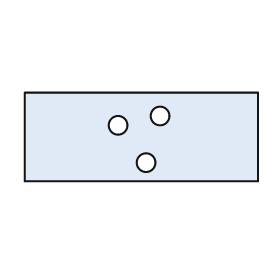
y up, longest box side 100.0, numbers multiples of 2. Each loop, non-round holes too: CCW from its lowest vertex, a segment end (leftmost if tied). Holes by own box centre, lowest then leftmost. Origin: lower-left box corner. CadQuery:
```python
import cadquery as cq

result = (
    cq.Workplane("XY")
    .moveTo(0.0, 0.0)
    .lineTo(100.0, 0.0)
    .lineTo(100.0, 38.0)
    .lineTo(0.0, 38.0)
    .close()
    .moveTo(52.0, 8.0)
    .circle(4.0)
    .moveTo(40.0, 24.0)
    .circle(4.0)
    .moveTo(58.0, 28.0)
    .circle(4.0)
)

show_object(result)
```